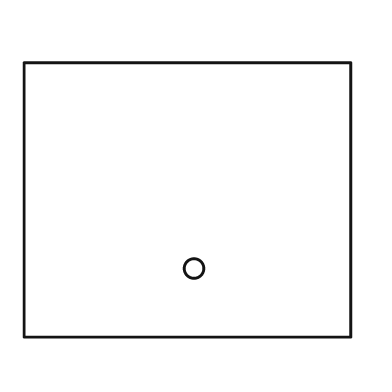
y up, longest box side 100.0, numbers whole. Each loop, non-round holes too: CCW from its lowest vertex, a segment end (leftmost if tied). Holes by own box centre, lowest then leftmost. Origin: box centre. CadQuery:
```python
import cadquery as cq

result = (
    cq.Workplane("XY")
    .moveTo(-50.0, -42.0)
    .lineTo(50.0, -42.0)
    .lineTo(50.0, 42.0)
    .lineTo(-50.0, 42.0)
    .close()
    .moveTo(2.0, -21.0)
    .circle(3.0)
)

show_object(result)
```